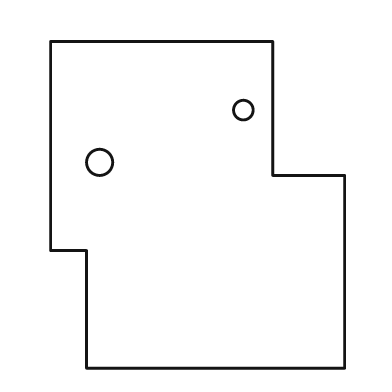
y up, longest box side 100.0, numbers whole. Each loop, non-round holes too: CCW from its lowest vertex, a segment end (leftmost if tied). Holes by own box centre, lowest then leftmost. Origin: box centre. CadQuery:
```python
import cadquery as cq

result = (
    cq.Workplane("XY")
    .moveTo(-34.0, -50.0)
    .lineTo(45.0, -50.0)
    .lineTo(45.0, 9.0)
    .lineTo(23.0, 9.0)
    .lineTo(23.0, 50.0)
    .lineTo(-45.0, 50.0)
    .lineTo(-45.0, -14.0)
    .lineTo(-34.0, -14.0)
    .close()
    .moveTo(-30.0, 13.0)
    .circle(4.0)
    .moveTo(14.0, 29.0)
    .circle(3.0)
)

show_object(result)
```